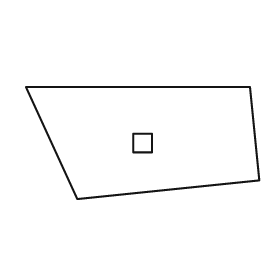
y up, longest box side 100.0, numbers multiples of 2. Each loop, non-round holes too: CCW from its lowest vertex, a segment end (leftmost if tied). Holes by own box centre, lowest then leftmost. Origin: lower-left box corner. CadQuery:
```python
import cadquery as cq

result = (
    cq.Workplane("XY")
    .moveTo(22.0, 0.0)
    .lineTo(100.0, 8.0)
    .lineTo(96.0, 48.0)
    .lineTo(0.0, 48.0)
    .close()
    .moveTo(46.0, 20.0)
    .lineTo(54.0, 20.0)
    .lineTo(54.0, 28.0)
    .lineTo(46.0, 28.0)
    .close()
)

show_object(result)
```